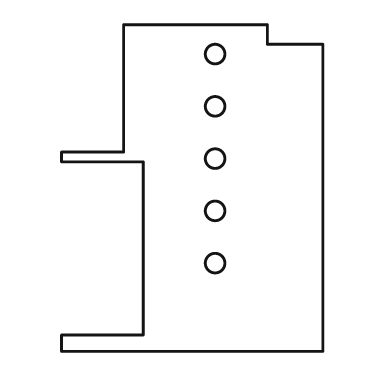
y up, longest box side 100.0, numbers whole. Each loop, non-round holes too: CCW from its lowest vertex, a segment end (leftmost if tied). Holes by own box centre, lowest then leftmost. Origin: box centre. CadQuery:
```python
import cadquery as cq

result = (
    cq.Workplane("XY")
    .moveTo(-40.0, -50.0)
    .lineTo(40.0, -50.0)
    .lineTo(40.0, 44.0)
    .lineTo(23.0, 44.0)
    .lineTo(23.0, 50.0)
    .lineTo(-21.0, 50.0)
    .lineTo(-21.0, 11.0)
    .lineTo(-40.0, 11.0)
    .lineTo(-40.0, 8.0)
    .lineTo(-15.0, 8.0)
    .lineTo(-15.0, -45.0)
    .lineTo(-40.0, -45.0)
    .close()
    .moveTo(7.0, -23.0)
    .circle(3.0)
    .moveTo(7.0, -7.0)
    .circle(3.0)
    .moveTo(7.0, 9.0)
    .circle(3.0)
    .moveTo(7.0, 25.0)
    .circle(3.0)
    .moveTo(7.0, 41.0)
    .circle(3.0)
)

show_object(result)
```